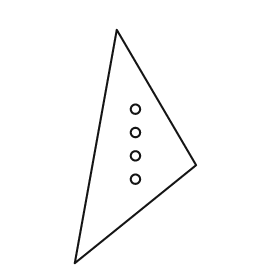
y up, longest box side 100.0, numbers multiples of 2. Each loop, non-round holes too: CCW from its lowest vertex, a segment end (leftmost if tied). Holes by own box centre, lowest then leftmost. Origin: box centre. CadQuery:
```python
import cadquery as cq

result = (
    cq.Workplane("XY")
    .moveTo(-26.0, -50.0)
    .lineTo(26.0, -8.0)
    .lineTo(-8.0, 50.0)
    .close()
    .moveTo(0.0, -14.0)
    .circle(2.0)
    .moveTo(0.0, -4.0)
    .circle(2.0)
    .moveTo(0.0, 6.0)
    .circle(2.0)
    .moveTo(0.0, 16.0)
    .circle(2.0)
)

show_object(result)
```